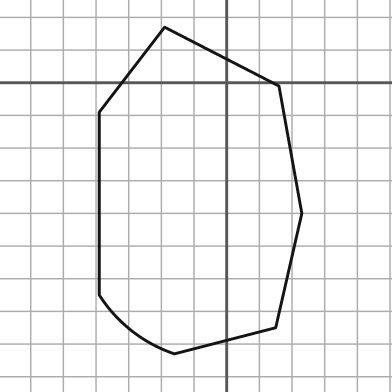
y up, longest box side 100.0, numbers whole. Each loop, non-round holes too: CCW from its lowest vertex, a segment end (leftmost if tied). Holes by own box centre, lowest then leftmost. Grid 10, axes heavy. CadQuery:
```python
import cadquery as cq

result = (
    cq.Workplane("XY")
    .moveTo(-16.0, -83.0)
    .lineTo(15.0, -75.0)
    .lineTo(23.0, -40.0)
    .lineTo(16.0, -1.0)
    .lineTo(-19.0, 17.0)
    .lineTo(-39.0, -9.0)
    .lineTo(-39.0, -65.0)
    .threePointArc((-29.0, -76.0), (-16.0, -83.0))
    .close()
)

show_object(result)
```